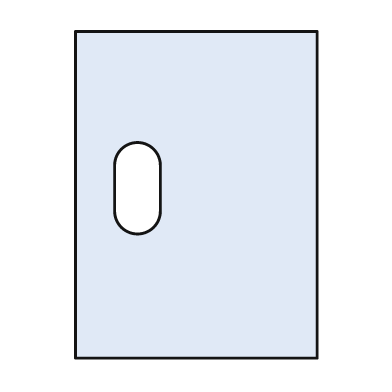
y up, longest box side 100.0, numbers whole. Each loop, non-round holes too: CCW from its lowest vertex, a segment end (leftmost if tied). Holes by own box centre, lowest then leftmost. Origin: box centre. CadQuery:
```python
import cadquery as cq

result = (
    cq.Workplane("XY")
    .moveTo(-37.0, -50.0)
    .lineTo(37.0, -50.0)
    .lineTo(37.0, 50.0)
    .lineTo(-37.0, 50.0)
    .close()
    .moveTo(-25.0, -5.0)
    .threePointArc((-18.0, -12.0), (-11.0, -5.0))
    .lineTo(-11.0, 9.0)
    .threePointArc((-18.0, 16.0), (-25.0, 9.0))
    .close()
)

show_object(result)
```